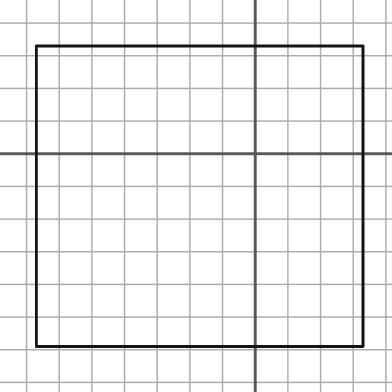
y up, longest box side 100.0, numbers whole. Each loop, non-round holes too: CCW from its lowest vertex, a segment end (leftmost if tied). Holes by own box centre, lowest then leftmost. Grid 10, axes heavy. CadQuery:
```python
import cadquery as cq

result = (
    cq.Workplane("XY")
    .moveTo(-67.0, -59.0)
    .lineTo(33.0, -59.0)
    .lineTo(33.0, 33.0)
    .lineTo(-67.0, 33.0)
    .close()
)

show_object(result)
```